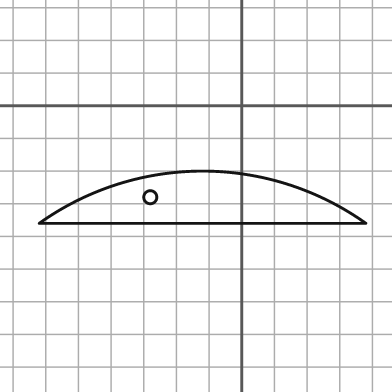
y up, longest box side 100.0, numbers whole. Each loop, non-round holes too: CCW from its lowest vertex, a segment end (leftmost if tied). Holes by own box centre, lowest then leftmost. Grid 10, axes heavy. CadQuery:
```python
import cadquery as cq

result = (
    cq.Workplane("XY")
    .moveTo(-62.0, -36.0)
    .lineTo(38.0, -36.0)
    .threePointArc((-12.0, -20.0), (-62.0, -36.0))
    .close()
    .moveTo(-28.0, -28.0)
    .circle(2.0)
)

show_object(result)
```